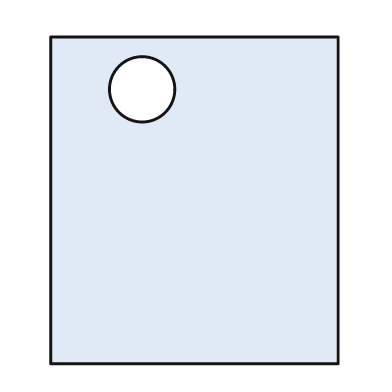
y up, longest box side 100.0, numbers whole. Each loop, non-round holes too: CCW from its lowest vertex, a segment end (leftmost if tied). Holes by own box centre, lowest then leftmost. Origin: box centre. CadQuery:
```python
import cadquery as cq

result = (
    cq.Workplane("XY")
    .moveTo(-44.0, -50.0)
    .lineTo(44.0, -50.0)
    .lineTo(44.0, 50.0)
    .lineTo(-44.0, 50.0)
    .close()
    .moveTo(-16.0, 34.0)
    .circle(10.0)
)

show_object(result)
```